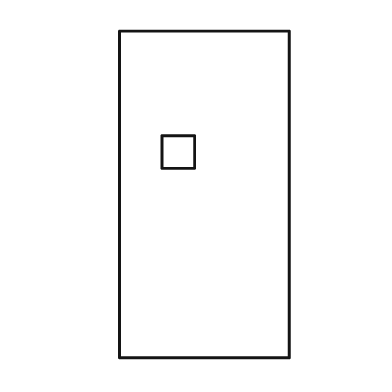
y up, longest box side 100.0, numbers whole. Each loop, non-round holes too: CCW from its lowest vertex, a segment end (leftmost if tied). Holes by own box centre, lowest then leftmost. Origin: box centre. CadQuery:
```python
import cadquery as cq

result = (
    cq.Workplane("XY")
    .moveTo(-26.0, -50.0)
    .lineTo(26.0, -50.0)
    .lineTo(26.0, 50.0)
    .lineTo(-26.0, 50.0)
    .close()
    .moveTo(-13.0, 8.0)
    .lineTo(-3.0, 8.0)
    .lineTo(-3.0, 18.0)
    .lineTo(-13.0, 18.0)
    .close()
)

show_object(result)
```